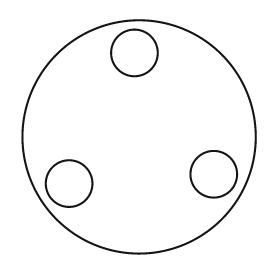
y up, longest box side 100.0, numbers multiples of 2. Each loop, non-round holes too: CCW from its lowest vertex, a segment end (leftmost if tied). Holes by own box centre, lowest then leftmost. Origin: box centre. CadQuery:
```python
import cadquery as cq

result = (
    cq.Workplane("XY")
    .moveTo(0.0, 0.0)
    .circle(50.0)
    .moveTo(-30.0, -20.0)
    .circle(10.0)
    .moveTo(32.0, -16.0)
    .circle(10.0)
    .moveTo(-2.0, 36.0)
    .circle(10.0)
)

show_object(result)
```